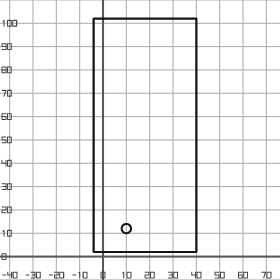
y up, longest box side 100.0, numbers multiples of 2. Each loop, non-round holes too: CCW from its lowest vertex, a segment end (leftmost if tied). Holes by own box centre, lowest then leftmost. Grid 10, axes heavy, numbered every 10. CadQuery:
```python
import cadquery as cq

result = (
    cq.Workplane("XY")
    .moveTo(-4.0, 2.0)
    .lineTo(40.0, 2.0)
    .lineTo(40.0, 102.0)
    .lineTo(-4.0, 102.0)
    .close()
    .moveTo(10.0, 12.0)
    .circle(2.0)
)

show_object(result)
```